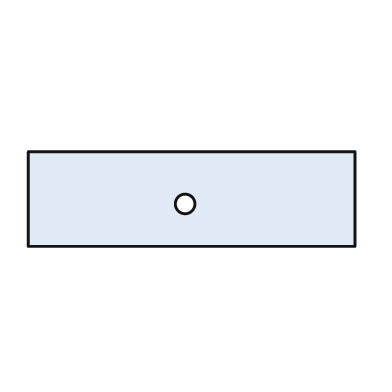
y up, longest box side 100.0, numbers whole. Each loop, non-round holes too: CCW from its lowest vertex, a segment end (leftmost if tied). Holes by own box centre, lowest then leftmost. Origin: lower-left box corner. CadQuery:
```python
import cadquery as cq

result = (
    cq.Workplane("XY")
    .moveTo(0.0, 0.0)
    .lineTo(100.0, 0.0)
    .lineTo(100.0, 29.0)
    .lineTo(0.0, 29.0)
    .close()
    .moveTo(48.0, 13.0)
    .circle(3.0)
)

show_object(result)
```